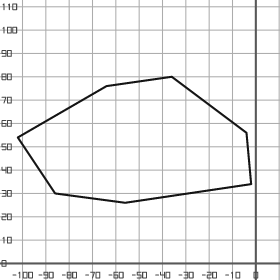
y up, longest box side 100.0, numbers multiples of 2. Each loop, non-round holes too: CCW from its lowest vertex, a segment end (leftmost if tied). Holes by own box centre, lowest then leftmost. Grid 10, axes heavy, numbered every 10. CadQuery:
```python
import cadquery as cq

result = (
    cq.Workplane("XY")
    .moveTo(-56.0, 26.0)
    .lineTo(-2.0, 34.0)
    .lineTo(-4.0, 56.0)
    .lineTo(-36.0, 80.0)
    .lineTo(-64.0, 76.0)
    .lineTo(-102.0, 54.0)
    .lineTo(-86.0, 30.0)
    .close()
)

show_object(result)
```